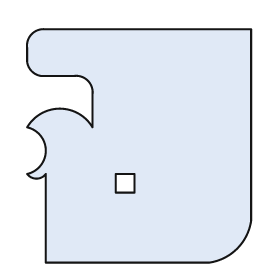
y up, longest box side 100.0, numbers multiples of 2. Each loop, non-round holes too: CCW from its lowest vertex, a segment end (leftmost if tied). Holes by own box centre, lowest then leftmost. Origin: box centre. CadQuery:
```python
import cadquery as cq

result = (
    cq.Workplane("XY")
    .moveTo(-40.0, -50.0)
    .lineTo(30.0, -50.0)
    .threePointArc((42.0, -44.0), (48.0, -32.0))
    .lineTo(48.0, 50.0)
    .lineTo(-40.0, 50.0)
    .threePointArc((-46.0, 48.0), (-48.0, 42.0))
    .lineTo(-48.0, 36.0)
    .threePointArc((-46.0, 32.0), (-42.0, 30.0))
    .lineTo(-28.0, 30.0)
    .threePointArc((-22.0, 28.0), (-20.0, 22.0))
    .lineTo(-20.0, 8.0)
    .threePointArc((-34.0, 16.0), (-48.0, 8.0))
    .threePointArc((-40.0, -2.0), (-48.0, -12.0))
    .threePointArc((-44.0, -14.0), (-40.0, -12.0))
    .close()
    .moveTo(-10.0, -20.0)
    .lineTo(-2.0, -20.0)
    .lineTo(-2.0, -12.0)
    .lineTo(-10.0, -12.0)
    .close()
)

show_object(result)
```